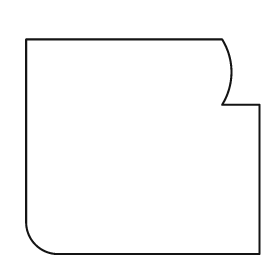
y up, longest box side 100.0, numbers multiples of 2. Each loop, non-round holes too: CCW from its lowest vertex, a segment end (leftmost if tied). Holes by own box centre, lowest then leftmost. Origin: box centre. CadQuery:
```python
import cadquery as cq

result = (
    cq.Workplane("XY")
    .moveTo(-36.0, -46.0)
    .lineTo(50.0, -46.0)
    .lineTo(50.0, 18.0)
    .lineTo(34.0, 18.0)
    .threePointArc((38.0, 32.0), (34.0, 46.0))
    .lineTo(-50.0, 46.0)
    .lineTo(-50.0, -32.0)
    .threePointArc((-46.0, -42.0), (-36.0, -46.0))
    .close()
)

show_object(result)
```